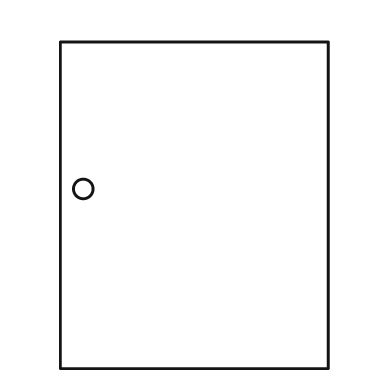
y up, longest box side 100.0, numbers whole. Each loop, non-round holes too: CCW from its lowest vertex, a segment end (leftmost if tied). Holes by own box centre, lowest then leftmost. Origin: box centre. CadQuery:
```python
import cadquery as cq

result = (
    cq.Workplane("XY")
    .moveTo(-41.0, -50.0)
    .lineTo(41.0, -50.0)
    .lineTo(41.0, 50.0)
    .lineTo(-41.0, 50.0)
    .close()
    .moveTo(-34.0, 5.0)
    .circle(3.0)
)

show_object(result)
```